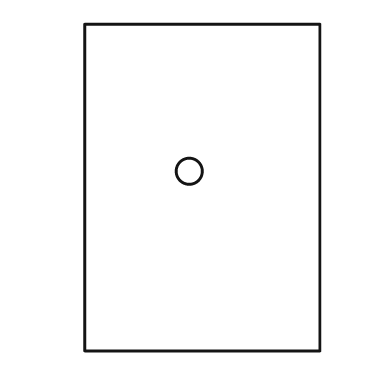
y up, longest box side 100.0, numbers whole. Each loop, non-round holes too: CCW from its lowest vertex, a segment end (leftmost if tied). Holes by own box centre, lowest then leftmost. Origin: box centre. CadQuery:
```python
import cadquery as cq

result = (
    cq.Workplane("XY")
    .moveTo(-36.0, -50.0)
    .lineTo(36.0, -50.0)
    .lineTo(36.0, 50.0)
    .lineTo(-36.0, 50.0)
    .close()
    .moveTo(-4.0, 5.0)
    .circle(4.0)
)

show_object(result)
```